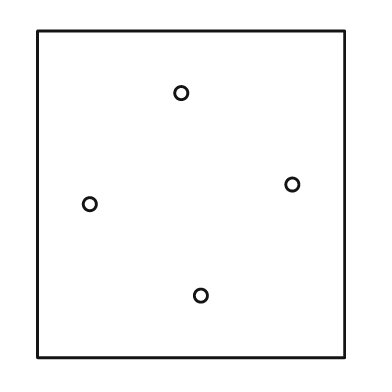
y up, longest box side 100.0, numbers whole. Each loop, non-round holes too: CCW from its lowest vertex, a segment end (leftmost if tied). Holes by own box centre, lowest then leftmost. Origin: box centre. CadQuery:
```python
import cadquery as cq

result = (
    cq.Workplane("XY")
    .moveTo(-47.0, -50.0)
    .lineTo(47.0, -50.0)
    .lineTo(47.0, 50.0)
    .lineTo(-47.0, 50.0)
    .close()
    .moveTo(3.0, -31.0)
    .circle(2.0)
    .moveTo(-31.0, -3.0)
    .circle(2.0)
    .moveTo(31.0, 3.0)
    .circle(2.0)
    .moveTo(-3.0, 31.0)
    .circle(2.0)
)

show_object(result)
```